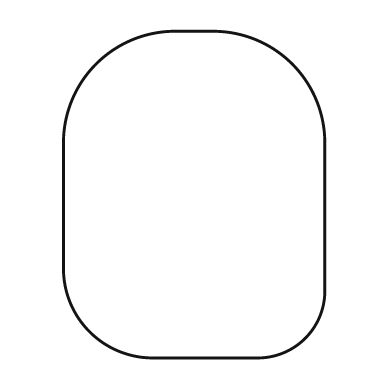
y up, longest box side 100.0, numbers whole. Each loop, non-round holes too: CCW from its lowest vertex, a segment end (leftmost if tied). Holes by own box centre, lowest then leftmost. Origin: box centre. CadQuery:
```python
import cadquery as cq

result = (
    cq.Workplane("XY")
    .moveTo(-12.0, -50.0)
    .lineTo(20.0, -50.0)
    .threePointArc((34.0, -44.0), (40.0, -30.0))
    .lineTo(40.0, 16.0)
    .threePointArc((30.0, 40.0), (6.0, 50.0))
    .lineTo(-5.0, 50.0)
    .threePointArc((-30.0, 40.0), (-40.0, 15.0))
    .lineTo(-40.0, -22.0)
    .threePointArc((-32.0, -42.0), (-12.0, -50.0))
    .close()
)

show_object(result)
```